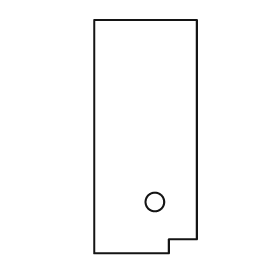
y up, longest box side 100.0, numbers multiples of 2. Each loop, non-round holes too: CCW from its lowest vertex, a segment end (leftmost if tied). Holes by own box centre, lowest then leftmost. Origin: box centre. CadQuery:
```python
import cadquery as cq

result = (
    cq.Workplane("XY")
    .moveTo(-22.0, -50.0)
    .lineTo(10.0, -50.0)
    .lineTo(10.0, -44.0)
    .lineTo(22.0, -44.0)
    .lineTo(22.0, 50.0)
    .lineTo(-22.0, 50.0)
    .close()
    .moveTo(4.0, -28.0)
    .circle(4.0)
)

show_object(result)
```